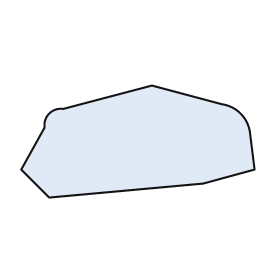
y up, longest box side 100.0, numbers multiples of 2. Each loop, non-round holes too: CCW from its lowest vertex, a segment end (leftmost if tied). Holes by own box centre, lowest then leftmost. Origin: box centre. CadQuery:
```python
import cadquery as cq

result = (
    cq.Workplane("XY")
    .moveTo(-38.0, -24.0)
    .lineTo(28.0, -18.0)
    .lineTo(50.0, -12.0)
    .lineTo(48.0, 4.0)
    .threePointArc((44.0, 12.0), (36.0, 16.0))
    .lineTo(6.0, 24.0)
    .lineTo(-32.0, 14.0)
    .threePointArc((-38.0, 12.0), (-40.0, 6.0))
    .lineTo(-50.0, -12.0)
    .close()
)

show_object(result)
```